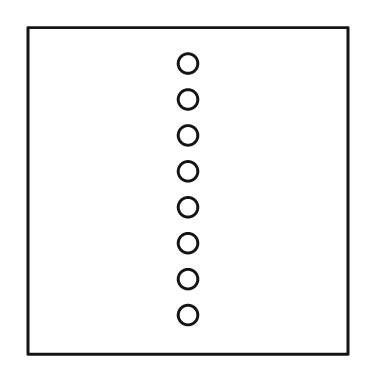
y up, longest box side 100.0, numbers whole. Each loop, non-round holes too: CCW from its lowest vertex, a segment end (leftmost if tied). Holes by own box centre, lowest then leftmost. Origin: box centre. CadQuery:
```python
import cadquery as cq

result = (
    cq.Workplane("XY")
    .moveTo(-49.0, -50.0)
    .lineTo(49.0, -50.0)
    .lineTo(49.0, 50.0)
    .lineTo(-49.0, 50.0)
    .close()
    .moveTo(0.0, -38.0)
    .circle(3.0)
    .moveTo(0.0, -27.0)
    .circle(3.0)
    .moveTo(0.0, -16.0)
    .circle(3.0)
    .moveTo(0.0, -5.0)
    .circle(3.0)
    .moveTo(0.0, 6.0)
    .circle(3.0)
    .moveTo(0.0, 17.0)
    .circle(3.0)
    .moveTo(0.0, 28.0)
    .circle(3.0)
    .moveTo(0.0, 39.0)
    .circle(3.0)
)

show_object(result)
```